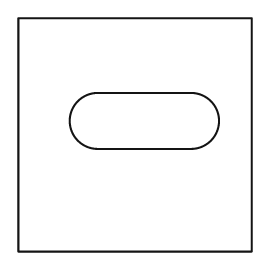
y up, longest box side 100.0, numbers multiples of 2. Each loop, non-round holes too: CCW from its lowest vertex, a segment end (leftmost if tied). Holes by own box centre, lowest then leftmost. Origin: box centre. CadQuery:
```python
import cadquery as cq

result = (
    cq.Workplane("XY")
    .moveTo(-50.0, -50.0)
    .lineTo(50.0, -50.0)
    .lineTo(50.0, 50.0)
    .lineTo(-50.0, 50.0)
    .close()
    .moveTo(-16.0, -6.0)
    .lineTo(24.0, -6.0)
    .threePointArc((36.0, 6.0), (24.0, 18.0))
    .lineTo(-16.0, 18.0)
    .threePointArc((-28.0, 6.0), (-16.0, -6.0))
    .close()
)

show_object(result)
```